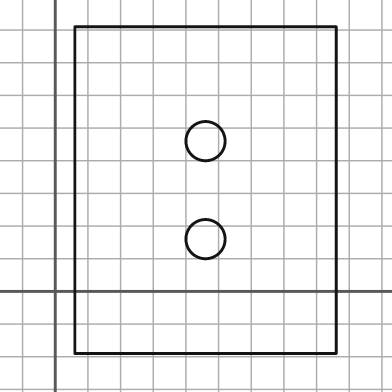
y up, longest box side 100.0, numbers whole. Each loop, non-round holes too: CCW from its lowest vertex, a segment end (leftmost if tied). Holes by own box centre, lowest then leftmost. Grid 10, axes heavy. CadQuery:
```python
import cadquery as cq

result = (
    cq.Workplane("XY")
    .moveTo(6.0, -19.0)
    .lineTo(86.0, -19.0)
    .lineTo(86.0, 81.0)
    .lineTo(6.0, 81.0)
    .close()
    .moveTo(46.0, 16.0)
    .circle(6.0)
    .moveTo(46.0, 46.0)
    .circle(6.0)
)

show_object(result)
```